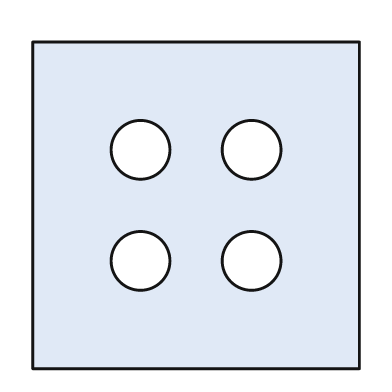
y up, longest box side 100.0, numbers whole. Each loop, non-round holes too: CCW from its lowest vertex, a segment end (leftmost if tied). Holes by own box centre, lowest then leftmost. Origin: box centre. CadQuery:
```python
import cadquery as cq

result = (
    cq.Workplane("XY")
    .moveTo(-50.0, -50.0)
    .lineTo(50.0, -50.0)
    .lineTo(50.0, 50.0)
    .lineTo(-50.0, 50.0)
    .close()
    .moveTo(-17.0, -17.0)
    .circle(9.0)
    .moveTo(17.0, -17.0)
    .circle(9.0)
    .moveTo(-17.0, 17.0)
    .circle(9.0)
    .moveTo(17.0, 17.0)
    .circle(9.0)
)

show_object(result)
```